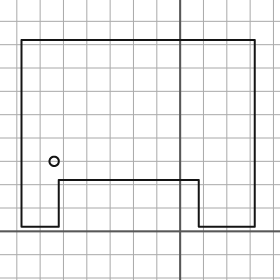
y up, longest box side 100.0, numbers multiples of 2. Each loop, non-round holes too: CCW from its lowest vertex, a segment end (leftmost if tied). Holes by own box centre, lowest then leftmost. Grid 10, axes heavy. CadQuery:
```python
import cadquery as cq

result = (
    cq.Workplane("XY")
    .moveTo(-68.0, 2.0)
    .lineTo(-52.0, 2.0)
    .lineTo(-52.0, 22.0)
    .lineTo(8.0, 22.0)
    .lineTo(8.0, 2.0)
    .lineTo(32.0, 2.0)
    .lineTo(32.0, 82.0)
    .lineTo(-68.0, 82.0)
    .close()
    .moveTo(-54.0, 30.0)
    .circle(2.0)
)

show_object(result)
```